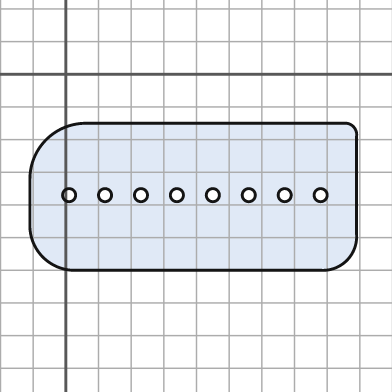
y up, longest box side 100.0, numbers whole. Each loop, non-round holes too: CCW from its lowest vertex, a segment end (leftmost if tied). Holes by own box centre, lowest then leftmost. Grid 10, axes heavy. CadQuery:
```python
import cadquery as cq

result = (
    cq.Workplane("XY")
    .moveTo(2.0, -60.0)
    .lineTo(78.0, -60.0)
    .threePointArc((86.0, -57.0), (89.0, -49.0))
    .lineTo(89.0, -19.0)
    .threePointArc((88.0, -16.0), (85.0, -15.0))
    .lineTo(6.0, -15.0)
    .threePointArc((-6.0, -20.0), (-11.0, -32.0))
    .lineTo(-11.0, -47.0)
    .threePointArc((-7.0, -56.0), (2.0, -60.0))
    .close()
    .moveTo(1.0, -37.0)
    .circle(2.0)
    .moveTo(12.0, -37.0)
    .circle(2.0)
    .moveTo(23.0, -37.0)
    .circle(2.0)
    .moveTo(34.0, -37.0)
    .circle(2.0)
    .moveTo(45.0, -37.0)
    .circle(2.0)
    .moveTo(56.0, -37.0)
    .circle(2.0)
    .moveTo(67.0, -37.0)
    .circle(2.0)
    .moveTo(78.0, -37.0)
    .circle(2.0)
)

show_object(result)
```